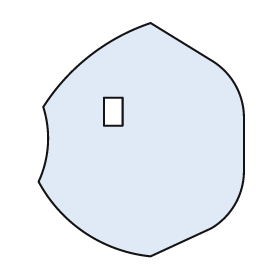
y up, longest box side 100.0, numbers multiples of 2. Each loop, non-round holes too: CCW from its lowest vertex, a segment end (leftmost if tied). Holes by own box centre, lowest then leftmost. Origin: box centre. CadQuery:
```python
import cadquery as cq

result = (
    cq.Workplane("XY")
    .moveTo(4.0, -50.0)
    .lineTo(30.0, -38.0)
    .threePointArc((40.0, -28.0), (44.0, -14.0))
    .lineTo(44.0, 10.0)
    .threePointArc((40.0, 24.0), (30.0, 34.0))
    .lineTo(4.0, 50.0)
    .threePointArc((-22.0, 36.0), (-42.0, 14.0))
    .threePointArc((-40.0, -2.0), (-44.0, -18.0))
    .threePointArc((-24.0, -40.0), (4.0, -50.0))
    .close()
    .moveTo(-16.0, 6.0)
    .lineTo(-8.0, 6.0)
    .lineTo(-8.0, 18.0)
    .lineTo(-16.0, 18.0)
    .close()
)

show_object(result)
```